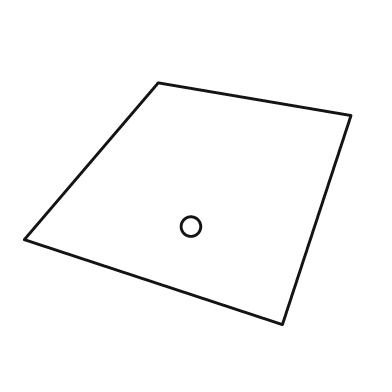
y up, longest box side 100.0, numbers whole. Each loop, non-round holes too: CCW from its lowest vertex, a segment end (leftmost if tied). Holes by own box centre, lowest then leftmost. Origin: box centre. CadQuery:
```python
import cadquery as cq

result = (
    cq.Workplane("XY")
    .moveTo(29.0, -37.0)
    .lineTo(50.0, 27.0)
    .lineTo(-9.0, 37.0)
    .lineTo(-50.0, -11.0)
    .close()
    .moveTo(1.0, -7.0)
    .circle(3.0)
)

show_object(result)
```